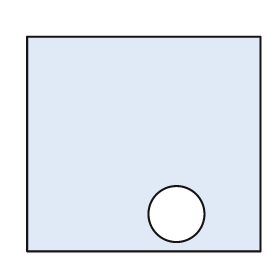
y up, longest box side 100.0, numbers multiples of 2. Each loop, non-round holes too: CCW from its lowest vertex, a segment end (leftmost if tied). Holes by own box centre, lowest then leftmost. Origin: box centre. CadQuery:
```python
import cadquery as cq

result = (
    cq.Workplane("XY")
    .moveTo(-50.0, -46.0)
    .lineTo(50.0, -46.0)
    .lineTo(50.0, 46.0)
    .lineTo(-50.0, 46.0)
    .close()
    .moveTo(14.0, -30.0)
    .circle(12.0)
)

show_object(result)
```